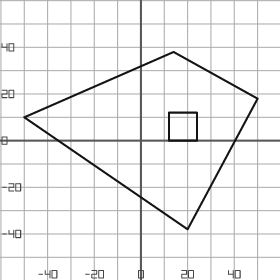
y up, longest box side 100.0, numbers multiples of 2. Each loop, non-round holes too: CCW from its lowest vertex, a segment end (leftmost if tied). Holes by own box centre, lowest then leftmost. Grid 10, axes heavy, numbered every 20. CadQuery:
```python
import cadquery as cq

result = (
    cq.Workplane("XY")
    .moveTo(20.0, -38.0)
    .lineTo(50.0, 18.0)
    .lineTo(14.0, 38.0)
    .lineTo(-50.0, 10.0)
    .close()
    .moveTo(12.0, 0.0)
    .lineTo(24.0, 0.0)
    .lineTo(24.0, 12.0)
    .lineTo(12.0, 12.0)
    .close()
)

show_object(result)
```